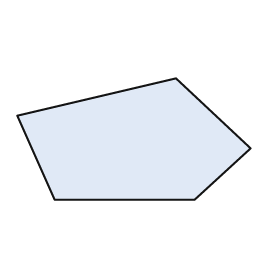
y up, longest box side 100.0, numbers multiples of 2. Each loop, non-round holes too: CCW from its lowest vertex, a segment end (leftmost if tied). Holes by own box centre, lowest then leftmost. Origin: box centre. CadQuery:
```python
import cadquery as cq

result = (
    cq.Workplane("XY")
    .moveTo(-34.0, -26.0)
    .lineTo(26.0, -26.0)
    .lineTo(50.0, -4.0)
    .lineTo(18.0, 26.0)
    .lineTo(-50.0, 10.0)
    .close()
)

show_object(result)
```